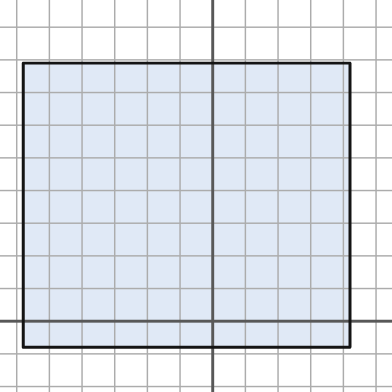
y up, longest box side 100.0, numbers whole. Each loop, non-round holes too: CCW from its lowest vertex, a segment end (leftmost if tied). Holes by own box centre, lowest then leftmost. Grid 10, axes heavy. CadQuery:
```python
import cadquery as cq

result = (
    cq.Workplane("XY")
    .moveTo(-58.0, -8.0)
    .lineTo(42.0, -8.0)
    .lineTo(42.0, 79.0)
    .lineTo(-58.0, 79.0)
    .close()
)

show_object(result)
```